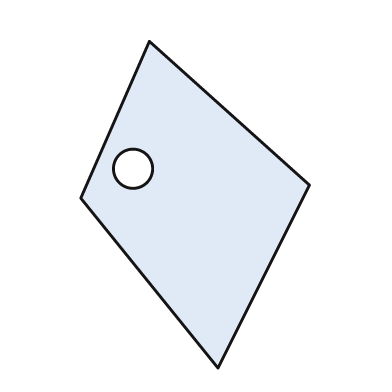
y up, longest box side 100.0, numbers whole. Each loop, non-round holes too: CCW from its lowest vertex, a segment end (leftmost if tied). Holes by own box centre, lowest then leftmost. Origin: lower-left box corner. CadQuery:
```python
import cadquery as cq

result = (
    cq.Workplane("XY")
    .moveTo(42.0, 0.0)
    .lineTo(70.0, 56.0)
    .lineTo(21.0, 100.0)
    .lineTo(0.0, 52.0)
    .close()
    .moveTo(16.0, 61.0)
    .circle(6.0)
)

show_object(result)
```